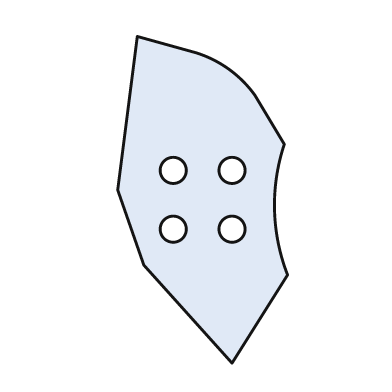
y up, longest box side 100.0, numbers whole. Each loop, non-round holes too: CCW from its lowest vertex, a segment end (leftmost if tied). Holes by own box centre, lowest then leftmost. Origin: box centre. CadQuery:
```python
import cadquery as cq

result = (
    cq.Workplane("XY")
    .moveTo(9.0, -50.0)
    .lineTo(26.0, -23.0)
    .threePointArc((22.0, -3.0), (25.0, 17.0))
    .lineTo(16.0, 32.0)
    .threePointArc((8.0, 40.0), (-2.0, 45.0))
    .lineTo(-20.0, 50.0)
    .lineTo(-26.0, 3.0)
    .lineTo(-18.0, -20.0)
    .close()
    .moveTo(-9.0, -9.0)
    .circle(4.0)
    .moveTo(9.0, -9.0)
    .circle(4.0)
    .moveTo(-9.0, 9.0)
    .circle(4.0)
    .moveTo(9.0, 9.0)
    .circle(4.0)
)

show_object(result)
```